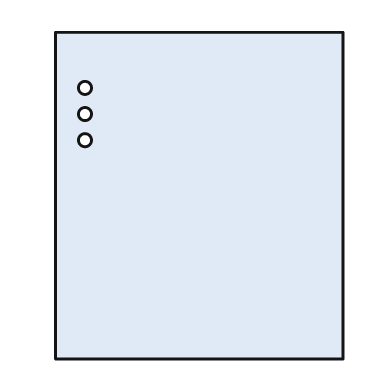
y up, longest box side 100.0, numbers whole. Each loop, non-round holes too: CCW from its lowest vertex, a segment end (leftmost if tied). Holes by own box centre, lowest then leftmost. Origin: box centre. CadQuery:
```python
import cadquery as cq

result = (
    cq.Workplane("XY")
    .moveTo(-44.0, -50.0)
    .lineTo(44.0, -50.0)
    .lineTo(44.0, 50.0)
    .lineTo(-44.0, 50.0)
    .close()
    .moveTo(-35.0, 17.0)
    .circle(2.0)
    .moveTo(-35.0, 25.0)
    .circle(2.0)
    .moveTo(-35.0, 33.0)
    .circle(2.0)
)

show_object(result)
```